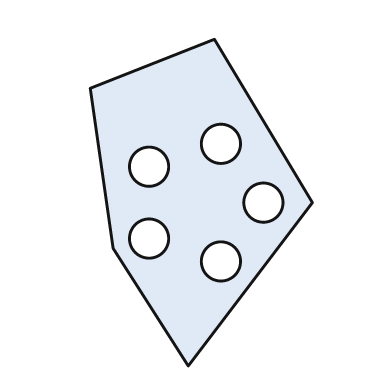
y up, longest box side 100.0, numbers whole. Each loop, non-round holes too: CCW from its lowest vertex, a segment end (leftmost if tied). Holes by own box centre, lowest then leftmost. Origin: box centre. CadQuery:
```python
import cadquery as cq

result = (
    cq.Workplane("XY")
    .moveTo(-4.0, -50.0)
    .lineTo(34.0, 0.0)
    .lineTo(4.0, 50.0)
    .lineTo(-34.0, 35.0)
    .lineTo(-27.0, -14.0)
    .close()
    .moveTo(6.0, -18.0)
    .circle(6.0)
    .moveTo(-16.0, -11.0)
    .circle(6.0)
    .moveTo(19.0, 0.0)
    .circle(6.0)
    .moveTo(-16.0, 11.0)
    .circle(6.0)
    .moveTo(6.0, 18.0)
    .circle(6.0)
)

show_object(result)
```